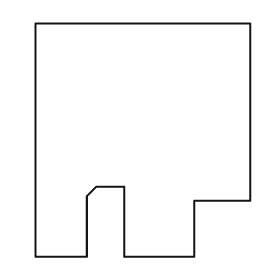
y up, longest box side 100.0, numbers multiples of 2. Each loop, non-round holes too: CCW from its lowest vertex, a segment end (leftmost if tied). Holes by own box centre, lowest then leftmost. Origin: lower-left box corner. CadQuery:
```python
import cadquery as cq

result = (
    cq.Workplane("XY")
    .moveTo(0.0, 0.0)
    .lineTo(22.0, 0.0)
    .lineTo(22.0, 26.0)
    .lineTo(26.0, 30.0)
    .lineTo(38.0, 30.0)
    .lineTo(38.0, 0.0)
    .lineTo(68.0, 0.0)
    .lineTo(68.0, 24.0)
    .lineTo(92.0, 24.0)
    .lineTo(92.0, 100.0)
    .lineTo(0.0, 100.0)
    .close()
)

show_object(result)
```